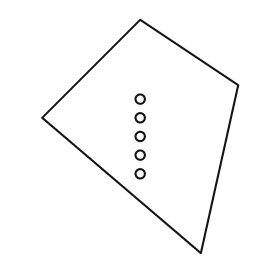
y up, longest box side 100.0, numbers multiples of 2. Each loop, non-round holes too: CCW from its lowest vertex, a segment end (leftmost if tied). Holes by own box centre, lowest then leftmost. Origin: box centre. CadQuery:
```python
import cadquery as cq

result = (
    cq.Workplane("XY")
    .moveTo(26.0, -50.0)
    .lineTo(42.0, 22.0)
    .lineTo(0.0, 50.0)
    .lineTo(-42.0, 8.0)
    .close()
    .moveTo(0.0, -16.0)
    .circle(2.0)
    .moveTo(0.0, -8.0)
    .circle(2.0)
    .moveTo(0.0, 0.0)
    .circle(2.0)
    .moveTo(0.0, 8.0)
    .circle(2.0)
    .moveTo(0.0, 16.0)
    .circle(2.0)
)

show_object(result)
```